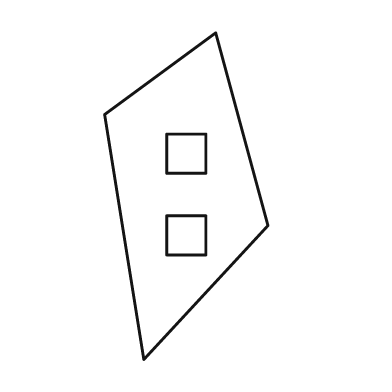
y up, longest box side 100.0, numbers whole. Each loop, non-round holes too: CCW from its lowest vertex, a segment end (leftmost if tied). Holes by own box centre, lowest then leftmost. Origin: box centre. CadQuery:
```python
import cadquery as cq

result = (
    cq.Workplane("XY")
    .moveTo(-13.0, -50.0)
    .lineTo(25.0, -9.0)
    .lineTo(9.0, 50.0)
    .lineTo(-25.0, 25.0)
    .close()
    .moveTo(-6.0, -18.0)
    .lineTo(6.0, -18.0)
    .lineTo(6.0, -6.0)
    .lineTo(-6.0, -6.0)
    .close()
    .moveTo(-6.0, 7.0)
    .lineTo(6.0, 7.0)
    .lineTo(6.0, 19.0)
    .lineTo(-6.0, 19.0)
    .close()
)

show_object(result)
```